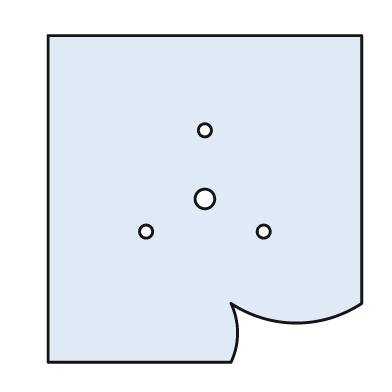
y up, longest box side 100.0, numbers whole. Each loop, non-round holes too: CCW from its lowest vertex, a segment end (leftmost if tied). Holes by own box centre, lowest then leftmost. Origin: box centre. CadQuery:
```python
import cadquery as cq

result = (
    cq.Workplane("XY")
    .moveTo(-48.0, -50.0)
    .lineTo(8.0, -50.0)
    .threePointArc((10.0, -41.0), (8.0, -32.0))
    .threePointArc((28.0, -38.0), (48.0, -32.0))
    .lineTo(48.0, 50.0)
    .lineTo(-48.0, 50.0)
    .close()
    .moveTo(-18.0, -10.0)
    .circle(2.0)
    .moveTo(18.0, -10.0)
    .circle(2.0)
    .moveTo(0.0, 0.0)
    .circle(3.0)
    .moveTo(0.0, 21.0)
    .circle(2.0)
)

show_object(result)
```